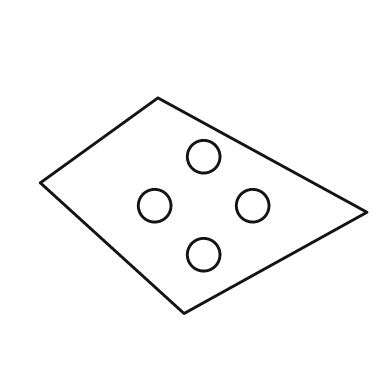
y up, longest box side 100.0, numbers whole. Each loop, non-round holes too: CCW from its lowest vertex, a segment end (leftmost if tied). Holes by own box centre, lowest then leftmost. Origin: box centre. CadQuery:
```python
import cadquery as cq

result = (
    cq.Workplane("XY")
    .moveTo(-6.0, -33.0)
    .lineTo(50.0, -2.0)
    .lineTo(-14.0, 33.0)
    .lineTo(-50.0, 7.0)
    .close()
    .moveTo(0.0, -15.0)
    .circle(5.0)
    .moveTo(-15.0, 0.0)
    .circle(5.0)
    .moveTo(15.0, 0.0)
    .circle(5.0)
    .moveTo(0.0, 15.0)
    .circle(5.0)
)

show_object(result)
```